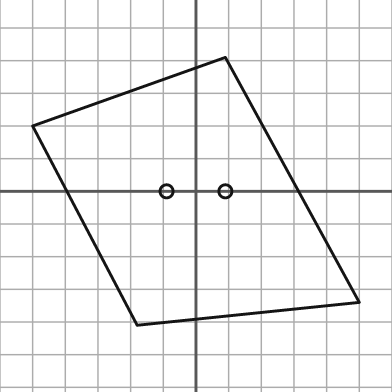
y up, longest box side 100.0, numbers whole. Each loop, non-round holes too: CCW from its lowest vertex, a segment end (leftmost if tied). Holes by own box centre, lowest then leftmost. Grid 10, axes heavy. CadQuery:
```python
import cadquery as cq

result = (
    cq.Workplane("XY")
    .moveTo(-18.0, -41.0)
    .lineTo(50.0, -34.0)
    .lineTo(9.0, 41.0)
    .lineTo(-50.0, 20.0)
    .close()
    .moveTo(-9.0, 0.0)
    .circle(2.0)
    .moveTo(9.0, 0.0)
    .circle(2.0)
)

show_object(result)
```